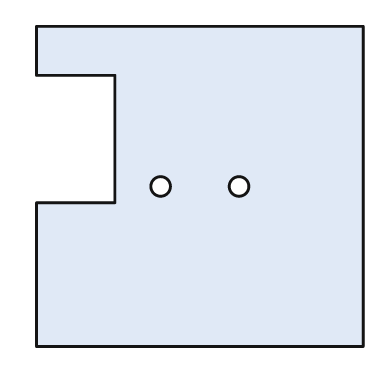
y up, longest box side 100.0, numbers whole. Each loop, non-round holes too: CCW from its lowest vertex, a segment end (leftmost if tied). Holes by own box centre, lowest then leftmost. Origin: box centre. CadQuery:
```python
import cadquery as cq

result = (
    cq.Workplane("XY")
    .moveTo(-50.0, -49.0)
    .lineTo(50.0, -49.0)
    .lineTo(50.0, 49.0)
    .lineTo(-50.0, 49.0)
    .lineTo(-50.0, 34.0)
    .lineTo(-26.0, 34.0)
    .lineTo(-26.0, -5.0)
    .lineTo(-50.0, -5.0)
    .close()
    .moveTo(-12.0, 0.0)
    .circle(3.0)
    .moveTo(12.0, 0.0)
    .circle(3.0)
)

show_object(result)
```